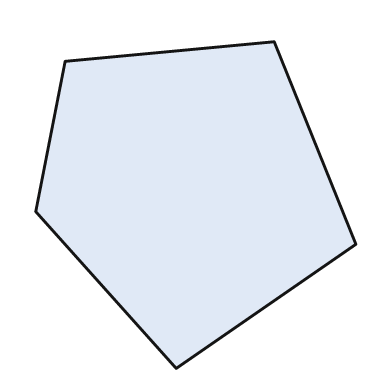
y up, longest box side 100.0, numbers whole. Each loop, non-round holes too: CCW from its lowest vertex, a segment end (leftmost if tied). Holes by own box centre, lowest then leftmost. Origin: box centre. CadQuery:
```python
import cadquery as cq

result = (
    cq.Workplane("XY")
    .moveTo(-6.0, -50.0)
    .lineTo(49.0, -12.0)
    .lineTo(24.0, 50.0)
    .lineTo(-40.0, 44.0)
    .lineTo(-49.0, -2.0)
    .close()
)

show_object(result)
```